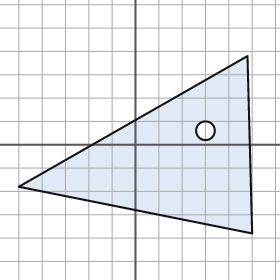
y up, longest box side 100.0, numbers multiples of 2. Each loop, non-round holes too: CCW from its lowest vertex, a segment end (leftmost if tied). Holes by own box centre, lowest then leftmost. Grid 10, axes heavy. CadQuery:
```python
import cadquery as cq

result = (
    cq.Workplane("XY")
    .moveTo(50.0, -38.0)
    .lineTo(48.0, 38.0)
    .lineTo(-50.0, -18.0)
    .close()
    .moveTo(30.0, 6.0)
    .circle(4.0)
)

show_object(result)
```